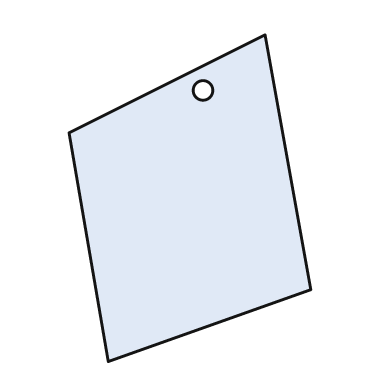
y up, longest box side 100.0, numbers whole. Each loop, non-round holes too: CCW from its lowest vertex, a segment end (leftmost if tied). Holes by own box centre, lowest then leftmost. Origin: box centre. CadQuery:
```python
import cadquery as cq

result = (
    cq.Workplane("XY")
    .moveTo(-25.0, -50.0)
    .lineTo(37.0, -28.0)
    .lineTo(23.0, 50.0)
    .lineTo(-37.0, 20.0)
    .close()
    .moveTo(4.0, 33.0)
    .circle(3.0)
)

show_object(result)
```